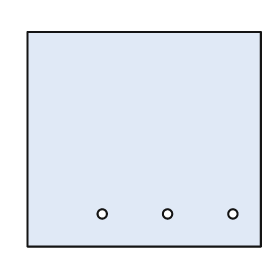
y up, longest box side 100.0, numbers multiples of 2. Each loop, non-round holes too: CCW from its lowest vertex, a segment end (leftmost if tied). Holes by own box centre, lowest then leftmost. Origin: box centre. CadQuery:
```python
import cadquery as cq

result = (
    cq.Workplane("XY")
    .moveTo(-50.0, -46.0)
    .lineTo(50.0, -46.0)
    .lineTo(50.0, 46.0)
    .lineTo(-50.0, 46.0)
    .close()
    .moveTo(-18.0, -32.0)
    .circle(2.0)
    .moveTo(10.0, -32.0)
    .circle(2.0)
    .moveTo(38.0, -32.0)
    .circle(2.0)
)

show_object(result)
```